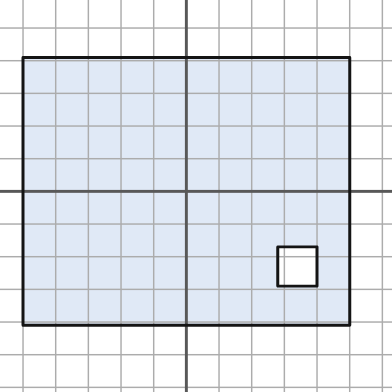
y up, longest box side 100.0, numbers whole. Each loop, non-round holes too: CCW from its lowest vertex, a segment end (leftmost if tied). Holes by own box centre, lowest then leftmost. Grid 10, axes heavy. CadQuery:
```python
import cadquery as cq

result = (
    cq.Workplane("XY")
    .moveTo(-50.0, -41.0)
    .lineTo(50.0, -41.0)
    .lineTo(50.0, 41.0)
    .lineTo(-50.0, 41.0)
    .close()
    .moveTo(28.0, -29.0)
    .lineTo(40.0, -29.0)
    .lineTo(40.0, -17.0)
    .lineTo(28.0, -17.0)
    .close()
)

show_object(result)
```